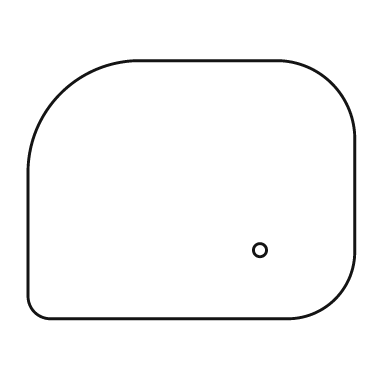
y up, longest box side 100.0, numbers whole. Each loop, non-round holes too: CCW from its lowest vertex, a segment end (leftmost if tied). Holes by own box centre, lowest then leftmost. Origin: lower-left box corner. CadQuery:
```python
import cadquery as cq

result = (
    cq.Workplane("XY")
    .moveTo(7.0, 0.0)
    .lineTo(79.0, 0.0)
    .threePointArc((94.0, 6.0), (100.0, 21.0))
    .lineTo(100.0, 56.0)
    .threePointArc((93.0, 72.0), (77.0, 79.0))
    .lineTo(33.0, 79.0)
    .threePointArc((10.0, 69.0), (0.0, 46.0))
    .lineTo(0.0, 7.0)
    .threePointArc((2.0, 2.0), (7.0, 0.0))
    .close()
    .moveTo(71.0, 21.0)
    .circle(2.0)
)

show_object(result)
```